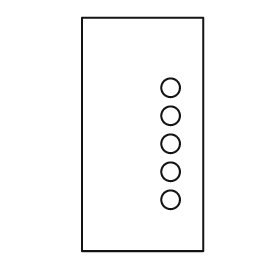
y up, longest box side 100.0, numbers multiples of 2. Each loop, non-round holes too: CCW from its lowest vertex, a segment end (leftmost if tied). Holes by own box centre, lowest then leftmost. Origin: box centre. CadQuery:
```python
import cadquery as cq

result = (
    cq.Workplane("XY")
    .moveTo(-26.0, -50.0)
    .lineTo(26.0, -50.0)
    .lineTo(26.0, 50.0)
    .lineTo(-26.0, 50.0)
    .close()
    .moveTo(12.0, -28.0)
    .circle(4.0)
    .moveTo(12.0, -16.0)
    .circle(4.0)
    .moveTo(12.0, -4.0)
    .circle(4.0)
    .moveTo(12.0, 8.0)
    .circle(4.0)
    .moveTo(12.0, 20.0)
    .circle(4.0)
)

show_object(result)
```